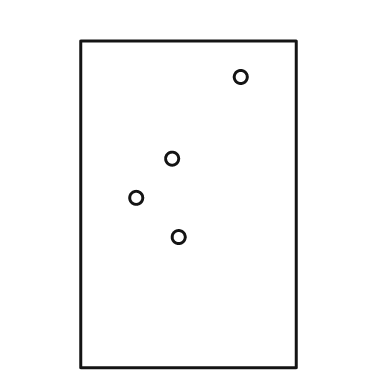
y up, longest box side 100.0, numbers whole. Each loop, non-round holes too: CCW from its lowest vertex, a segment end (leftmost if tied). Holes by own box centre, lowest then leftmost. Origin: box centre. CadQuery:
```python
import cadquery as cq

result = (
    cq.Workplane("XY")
    .moveTo(-33.0, -50.0)
    .lineTo(33.0, -50.0)
    .lineTo(33.0, 50.0)
    .lineTo(-33.0, 50.0)
    .close()
    .moveTo(-3.0, -10.0)
    .circle(2.0)
    .moveTo(-16.0, 2.0)
    .circle(2.0)
    .moveTo(-5.0, 14.0)
    .circle(2.0)
    .moveTo(16.0, 39.0)
    .circle(2.0)
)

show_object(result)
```